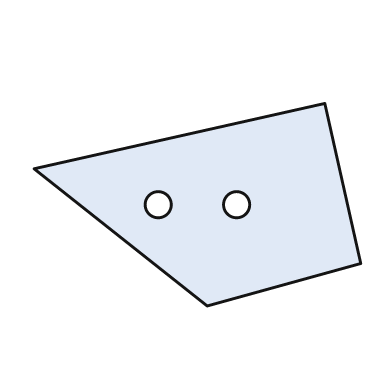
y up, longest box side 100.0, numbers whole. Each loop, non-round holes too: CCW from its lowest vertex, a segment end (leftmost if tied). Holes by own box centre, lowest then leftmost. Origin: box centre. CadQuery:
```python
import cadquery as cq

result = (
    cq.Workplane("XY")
    .moveTo(3.0, -31.0)
    .lineTo(50.0, -18.0)
    .lineTo(39.0, 31.0)
    .lineTo(-50.0, 11.0)
    .close()
    .moveTo(-12.0, 0.0)
    .circle(4.0)
    .moveTo(12.0, 0.0)
    .circle(4.0)
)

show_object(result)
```